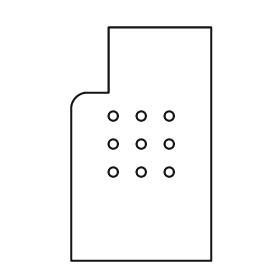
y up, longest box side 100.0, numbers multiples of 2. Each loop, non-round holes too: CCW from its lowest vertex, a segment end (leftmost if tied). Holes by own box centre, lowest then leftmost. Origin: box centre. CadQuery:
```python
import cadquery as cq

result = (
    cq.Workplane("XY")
    .moveTo(-30.0, -50.0)
    .lineTo(30.0, -50.0)
    .lineTo(30.0, 50.0)
    .lineTo(-14.0, 50.0)
    .lineTo(-14.0, 22.0)
    .lineTo(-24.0, 22.0)
    .threePointArc((-28.0, 20.0), (-30.0, 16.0))
    .close()
    .moveTo(-12.0, -12.0)
    .circle(2.0)
    .moveTo(0.0, -12.0)
    .circle(2.0)
    .moveTo(12.0, -12.0)
    .circle(2.0)
    .moveTo(-12.0, 0.0)
    .circle(2.0)
    .moveTo(0.0, 0.0)
    .circle(2.0)
    .moveTo(12.0, 0.0)
    .circle(2.0)
    .moveTo(-12.0, 12.0)
    .circle(2.0)
    .moveTo(0.0, 12.0)
    .circle(2.0)
    .moveTo(12.0, 12.0)
    .circle(2.0)
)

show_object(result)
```